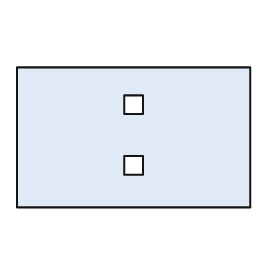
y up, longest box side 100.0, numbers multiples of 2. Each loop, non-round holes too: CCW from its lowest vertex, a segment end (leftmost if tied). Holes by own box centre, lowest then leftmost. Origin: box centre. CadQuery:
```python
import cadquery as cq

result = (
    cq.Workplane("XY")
    .moveTo(-50.0, -30.0)
    .lineTo(50.0, -30.0)
    .lineTo(50.0, 30.0)
    .lineTo(-50.0, 30.0)
    .close()
    .moveTo(-4.0, -16.0)
    .lineTo(4.0, -16.0)
    .lineTo(4.0, -8.0)
    .lineTo(-4.0, -8.0)
    .close()
    .moveTo(-4.0, 10.0)
    .lineTo(4.0, 10.0)
    .lineTo(4.0, 18.0)
    .lineTo(-4.0, 18.0)
    .close()
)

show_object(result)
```